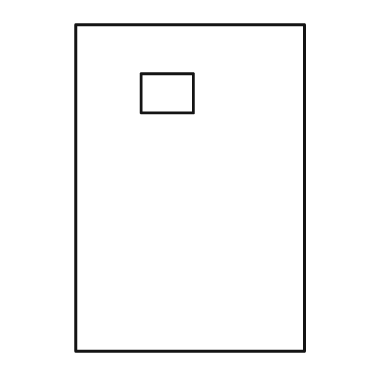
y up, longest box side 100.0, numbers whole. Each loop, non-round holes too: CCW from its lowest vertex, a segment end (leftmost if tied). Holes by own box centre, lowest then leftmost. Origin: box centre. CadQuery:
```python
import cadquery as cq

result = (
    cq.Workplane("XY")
    .moveTo(-35.0, -50.0)
    .lineTo(35.0, -50.0)
    .lineTo(35.0, 50.0)
    .lineTo(-35.0, 50.0)
    .close()
    .moveTo(-15.0, 23.0)
    .lineTo(1.0, 23.0)
    .lineTo(1.0, 35.0)
    .lineTo(-15.0, 35.0)
    .close()
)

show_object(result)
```